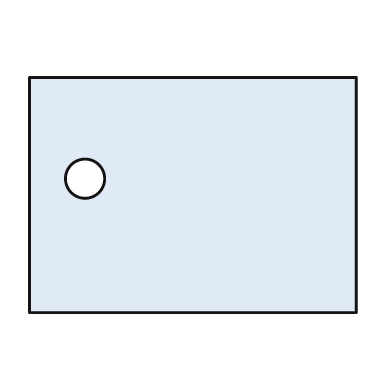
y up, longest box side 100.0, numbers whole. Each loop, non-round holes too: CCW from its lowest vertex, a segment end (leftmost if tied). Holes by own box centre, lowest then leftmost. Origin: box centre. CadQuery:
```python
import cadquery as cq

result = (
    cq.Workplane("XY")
    .moveTo(-50.0, -36.0)
    .lineTo(50.0, -36.0)
    .lineTo(50.0, 36.0)
    .lineTo(-50.0, 36.0)
    .close()
    .moveTo(-33.0, 5.0)
    .circle(6.0)
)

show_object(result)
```